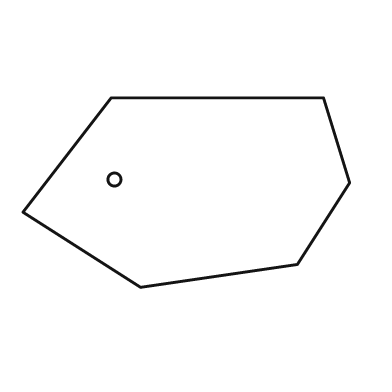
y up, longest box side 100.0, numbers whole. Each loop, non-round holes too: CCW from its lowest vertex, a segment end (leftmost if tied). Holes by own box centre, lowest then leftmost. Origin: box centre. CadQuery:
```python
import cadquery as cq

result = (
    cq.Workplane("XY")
    .moveTo(-14.0, -29.0)
    .lineTo(34.0, -22.0)
    .lineTo(50.0, 3.0)
    .lineTo(42.0, 29.0)
    .lineTo(-23.0, 29.0)
    .lineTo(-50.0, -6.0)
    .close()
    .moveTo(-22.0, 4.0)
    .circle(2.0)
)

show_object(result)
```